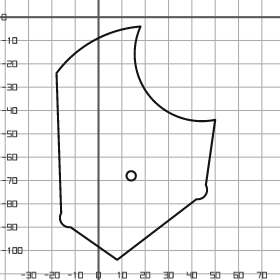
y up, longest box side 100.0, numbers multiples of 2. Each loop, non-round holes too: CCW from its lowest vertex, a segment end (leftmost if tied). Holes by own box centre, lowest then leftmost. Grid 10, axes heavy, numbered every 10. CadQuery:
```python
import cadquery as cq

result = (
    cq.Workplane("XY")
    .moveTo(8.0, -104.0)
    .lineTo(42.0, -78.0)
    .threePointArc((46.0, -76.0), (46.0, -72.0))
    .lineTo(50.0, -44.0)
    .threePointArc((22.0, -34.0), (18.0, -4.0))
    .threePointArc((-2.0, -10.0), (-18.0, -24.0))
    .lineTo(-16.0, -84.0)
    .threePointArc((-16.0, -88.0), (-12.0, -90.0))
    .close()
    .moveTo(14.0, -68.0)
    .circle(2.0)
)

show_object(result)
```